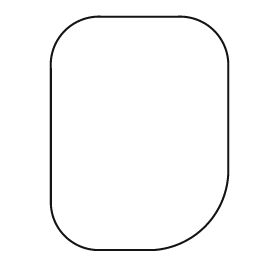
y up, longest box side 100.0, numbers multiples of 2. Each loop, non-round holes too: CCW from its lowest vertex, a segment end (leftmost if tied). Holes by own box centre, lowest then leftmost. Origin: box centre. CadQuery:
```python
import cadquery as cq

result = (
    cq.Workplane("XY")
    .moveTo(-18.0, -50.0)
    .lineTo(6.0, -50.0)
    .threePointArc((28.0, -40.0), (38.0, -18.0))
    .lineTo(38.0, 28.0)
    .threePointArc((32.0, 44.0), (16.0, 50.0))
    .lineTo(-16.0, 50.0)
    .threePointArc((-32.0, 44.0), (-38.0, 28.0))
    .lineTo(-38.0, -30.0)
    .threePointArc((-32.0, -44.0), (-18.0, -50.0))
    .close()
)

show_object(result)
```